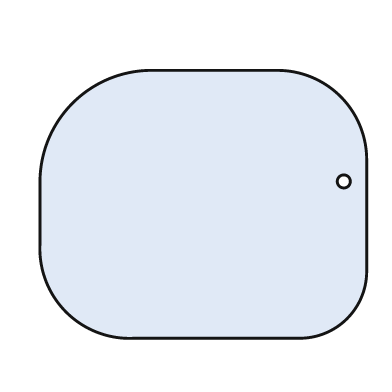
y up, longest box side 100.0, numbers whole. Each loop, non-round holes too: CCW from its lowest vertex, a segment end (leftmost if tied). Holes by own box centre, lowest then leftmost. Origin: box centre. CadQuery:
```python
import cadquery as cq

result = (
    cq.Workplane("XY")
    .moveTo(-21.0, -41.0)
    .lineTo(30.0, -41.0)
    .threePointArc((44.0, -35.0), (50.0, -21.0))
    .lineTo(50.0, 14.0)
    .threePointArc((42.0, 33.0), (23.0, 41.0))
    .lineTo(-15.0, 41.0)
    .threePointArc((-40.0, 31.0), (-50.0, 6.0))
    .lineTo(-50.0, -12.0)
    .threePointArc((-42.0, -33.0), (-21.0, -41.0))
    .close()
    .moveTo(43.0, 7.0)
    .circle(2.0)
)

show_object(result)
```